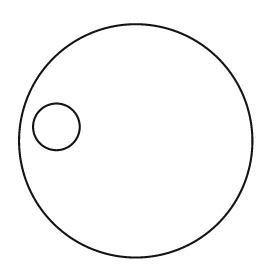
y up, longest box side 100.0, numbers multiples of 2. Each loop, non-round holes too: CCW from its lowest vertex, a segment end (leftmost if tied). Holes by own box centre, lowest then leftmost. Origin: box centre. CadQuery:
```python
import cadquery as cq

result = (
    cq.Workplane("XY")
    .moveTo(0.0, 0.0)
    .circle(50.0)
    .moveTo(-34.0, 6.0)
    .circle(10.0)
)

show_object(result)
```